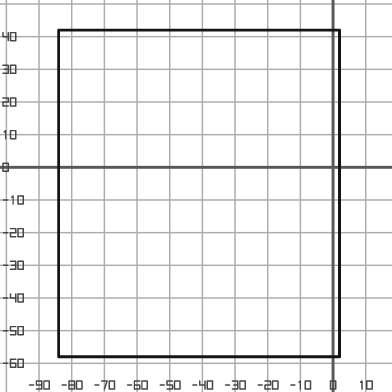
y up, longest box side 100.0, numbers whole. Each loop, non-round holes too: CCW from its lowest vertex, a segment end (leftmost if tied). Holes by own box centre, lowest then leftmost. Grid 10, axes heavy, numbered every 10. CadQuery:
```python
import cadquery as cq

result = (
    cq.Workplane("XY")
    .moveTo(-84.0, -58.0)
    .lineTo(2.0, -58.0)
    .lineTo(2.0, 42.0)
    .lineTo(-84.0, 42.0)
    .close()
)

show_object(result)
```